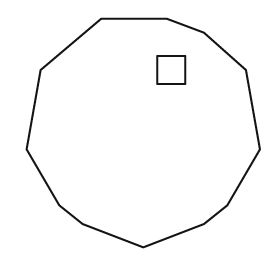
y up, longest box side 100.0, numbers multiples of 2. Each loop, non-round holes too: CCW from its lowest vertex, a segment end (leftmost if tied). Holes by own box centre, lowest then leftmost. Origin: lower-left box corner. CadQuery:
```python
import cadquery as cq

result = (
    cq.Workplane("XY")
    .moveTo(50.0, 0.0)
    .lineTo(76.0, 10.0)
    .lineTo(86.0, 18.0)
    .lineTo(100.0, 42.0)
    .lineTo(94.0, 76.0)
    .lineTo(76.0, 92.0)
    .lineTo(60.0, 98.0)
    .lineTo(32.0, 98.0)
    .lineTo(6.0, 76.0)
    .lineTo(0.0, 42.0)
    .lineTo(14.0, 18.0)
    .lineTo(24.0, 10.0)
    .close()
    .moveTo(56.0, 70.0)
    .lineTo(68.0, 70.0)
    .lineTo(68.0, 82.0)
    .lineTo(56.0, 82.0)
    .close()
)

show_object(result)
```